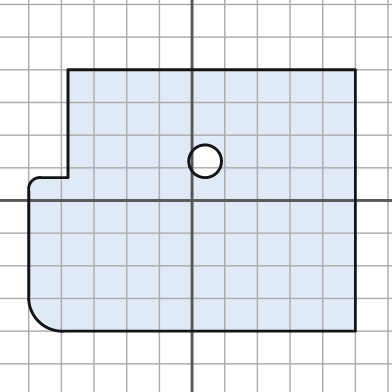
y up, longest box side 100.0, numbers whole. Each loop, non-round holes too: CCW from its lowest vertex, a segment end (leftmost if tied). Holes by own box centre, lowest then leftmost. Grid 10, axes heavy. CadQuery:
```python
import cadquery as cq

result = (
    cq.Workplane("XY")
    .moveTo(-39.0, -40.0)
    .lineTo(50.0, -40.0)
    .lineTo(50.0, 40.0)
    .lineTo(-38.0, 40.0)
    .lineTo(-38.0, 7.0)
    .lineTo(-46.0, 7.0)
    .threePointArc((-49.0, 6.0), (-50.0, 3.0))
    .lineTo(-50.0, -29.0)
    .threePointArc((-47.0, -37.0), (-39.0, -40.0))
    .close()
    .moveTo(4.0, 12.0)
    .circle(5.0)
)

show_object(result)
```